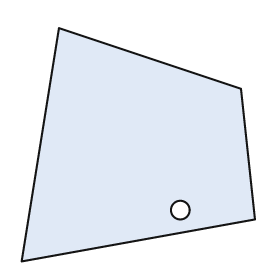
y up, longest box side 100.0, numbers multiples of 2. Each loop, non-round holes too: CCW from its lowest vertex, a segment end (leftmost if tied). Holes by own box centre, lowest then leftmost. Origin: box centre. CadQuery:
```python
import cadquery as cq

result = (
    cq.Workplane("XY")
    .moveTo(-50.0, -50.0)
    .lineTo(50.0, -32.0)
    .lineTo(44.0, 24.0)
    .lineTo(-34.0, 50.0)
    .close()
    .moveTo(18.0, -28.0)
    .circle(4.0)
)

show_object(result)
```